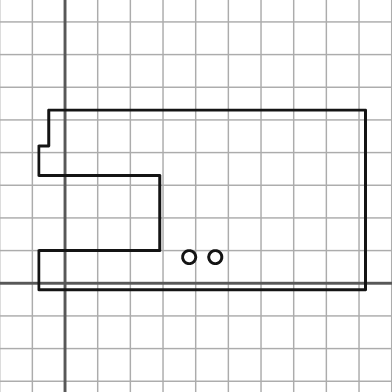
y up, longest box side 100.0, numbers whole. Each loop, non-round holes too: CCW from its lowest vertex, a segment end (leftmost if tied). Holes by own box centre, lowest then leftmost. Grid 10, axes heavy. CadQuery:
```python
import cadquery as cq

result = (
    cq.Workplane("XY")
    .moveTo(-8.0, -2.0)
    .lineTo(92.0, -2.0)
    .lineTo(92.0, 53.0)
    .lineTo(-5.0, 53.0)
    .lineTo(-5.0, 42.0)
    .lineTo(-8.0, 42.0)
    .lineTo(-8.0, 33.0)
    .lineTo(29.0, 33.0)
    .lineTo(29.0, 10.0)
    .lineTo(-8.0, 10.0)
    .close()
    .moveTo(38.0, 8.0)
    .circle(2.0)
    .moveTo(46.0, 8.0)
    .circle(2.0)
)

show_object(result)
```